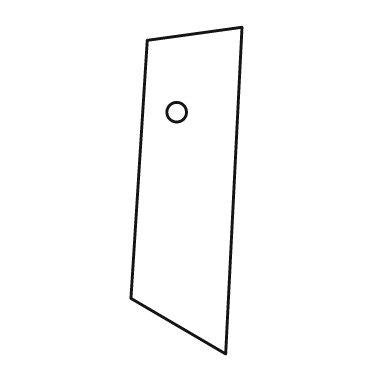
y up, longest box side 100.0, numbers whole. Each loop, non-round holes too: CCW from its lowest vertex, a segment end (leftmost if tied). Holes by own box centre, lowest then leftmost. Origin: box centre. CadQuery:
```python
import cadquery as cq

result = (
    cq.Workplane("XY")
    .moveTo(12.0, -50.0)
    .lineTo(17.0, 50.0)
    .lineTo(-12.0, 46.0)
    .lineTo(-17.0, -33.0)
    .close()
    .moveTo(-3.0, 24.0)
    .circle(3.0)
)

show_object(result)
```